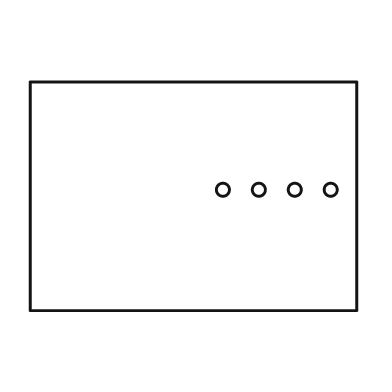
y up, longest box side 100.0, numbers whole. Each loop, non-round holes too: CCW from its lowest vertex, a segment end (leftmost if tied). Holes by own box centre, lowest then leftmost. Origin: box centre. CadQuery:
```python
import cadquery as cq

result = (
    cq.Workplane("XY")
    .moveTo(-50.0, -35.0)
    .lineTo(50.0, -35.0)
    .lineTo(50.0, 35.0)
    .lineTo(-50.0, 35.0)
    .close()
    .moveTo(9.0, 2.0)
    .circle(2.0)
    .moveTo(20.0, 2.0)
    .circle(2.0)
    .moveTo(31.0, 2.0)
    .circle(2.0)
    .moveTo(42.0, 2.0)
    .circle(2.0)
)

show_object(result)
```